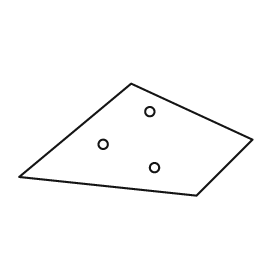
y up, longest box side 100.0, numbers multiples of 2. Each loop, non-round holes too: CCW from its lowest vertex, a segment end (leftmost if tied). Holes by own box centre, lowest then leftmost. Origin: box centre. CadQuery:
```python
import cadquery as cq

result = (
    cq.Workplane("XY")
    .moveTo(26.0, -24.0)
    .lineTo(50.0, 0.0)
    .lineTo(-2.0, 24.0)
    .lineTo(-50.0, -16.0)
    .close()
    .moveTo(8.0, -12.0)
    .circle(2.0)
    .moveTo(-14.0, -2.0)
    .circle(2.0)
    .moveTo(6.0, 12.0)
    .circle(2.0)
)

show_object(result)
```